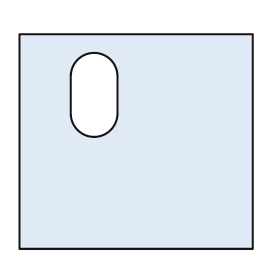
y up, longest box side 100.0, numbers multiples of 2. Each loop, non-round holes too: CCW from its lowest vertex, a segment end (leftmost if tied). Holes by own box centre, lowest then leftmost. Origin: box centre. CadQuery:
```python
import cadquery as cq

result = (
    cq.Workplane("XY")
    .moveTo(-50.0, -46.0)
    .lineTo(50.0, -46.0)
    .lineTo(50.0, 46.0)
    .lineTo(-50.0, 46.0)
    .close()
    .moveTo(-28.0, 12.0)
    .threePointArc((-18.0, 2.0), (-8.0, 12.0))
    .lineTo(-8.0, 28.0)
    .threePointArc((-18.0, 38.0), (-28.0, 28.0))
    .close()
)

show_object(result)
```